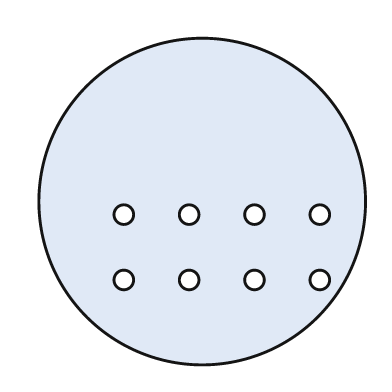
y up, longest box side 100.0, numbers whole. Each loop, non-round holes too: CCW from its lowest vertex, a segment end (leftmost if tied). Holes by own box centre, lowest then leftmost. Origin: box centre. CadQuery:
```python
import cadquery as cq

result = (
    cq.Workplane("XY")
    .moveTo(0.0, 0.0)
    .circle(50.0)
    .moveTo(-24.0, -24.0)
    .circle(3.0)
    .moveTo(-4.0, -24.0)
    .circle(3.0)
    .moveTo(16.0, -24.0)
    .circle(3.0)
    .moveTo(36.0, -24.0)
    .circle(3.0)
    .moveTo(-24.0, -4.0)
    .circle(3.0)
    .moveTo(-4.0, -4.0)
    .circle(3.0)
    .moveTo(16.0, -4.0)
    .circle(3.0)
    .moveTo(36.0, -4.0)
    .circle(3.0)
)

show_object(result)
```